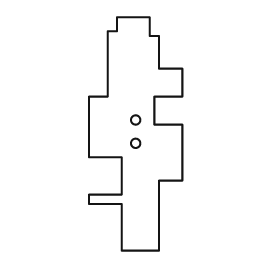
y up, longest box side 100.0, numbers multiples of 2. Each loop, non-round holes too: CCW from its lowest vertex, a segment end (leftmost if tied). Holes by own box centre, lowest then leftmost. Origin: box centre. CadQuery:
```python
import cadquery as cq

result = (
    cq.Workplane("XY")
    .moveTo(-6.0, -50.0)
    .lineTo(10.0, -50.0)
    .lineTo(10.0, -20.0)
    .lineTo(20.0, -20.0)
    .lineTo(20.0, 4.0)
    .lineTo(8.0, 4.0)
    .lineTo(8.0, 16.0)
    .lineTo(20.0, 16.0)
    .lineTo(20.0, 28.0)
    .lineTo(10.0, 28.0)
    .lineTo(10.0, 42.0)
    .lineTo(6.0, 42.0)
    .lineTo(6.0, 50.0)
    .lineTo(-8.0, 50.0)
    .lineTo(-8.0, 44.0)
    .lineTo(-12.0, 44.0)
    .lineTo(-12.0, 16.0)
    .lineTo(-20.0, 16.0)
    .lineTo(-20.0, -10.0)
    .lineTo(-6.0, -10.0)
    .lineTo(-6.0, -26.0)
    .lineTo(-20.0, -26.0)
    .lineTo(-20.0, -30.0)
    .lineTo(-6.0, -30.0)
    .close()
    .moveTo(0.0, -4.0)
    .circle(2.0)
    .moveTo(0.0, 6.0)
    .circle(2.0)
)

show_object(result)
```